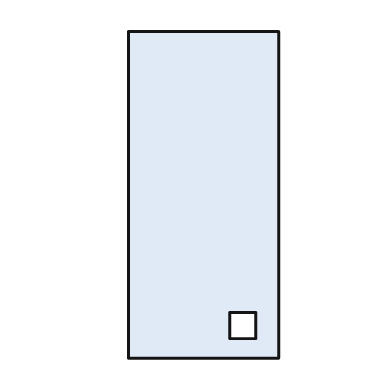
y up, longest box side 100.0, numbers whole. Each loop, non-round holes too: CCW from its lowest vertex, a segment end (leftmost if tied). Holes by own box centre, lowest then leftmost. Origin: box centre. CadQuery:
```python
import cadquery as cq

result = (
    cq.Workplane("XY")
    .moveTo(-23.0, -50.0)
    .lineTo(23.0, -50.0)
    .lineTo(23.0, 50.0)
    .lineTo(-23.0, 50.0)
    .close()
    .moveTo(8.0, -44.0)
    .lineTo(16.0, -44.0)
    .lineTo(16.0, -36.0)
    .lineTo(8.0, -36.0)
    .close()
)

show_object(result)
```